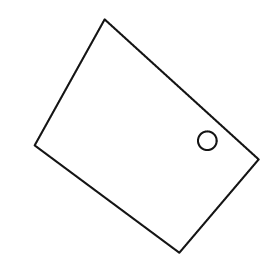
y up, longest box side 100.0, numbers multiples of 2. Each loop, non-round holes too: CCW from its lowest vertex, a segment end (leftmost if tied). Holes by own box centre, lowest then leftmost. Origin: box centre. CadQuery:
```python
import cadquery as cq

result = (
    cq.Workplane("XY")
    .moveTo(14.0, -50.0)
    .lineTo(48.0, -10.0)
    .lineTo(-18.0, 50.0)
    .lineTo(-48.0, -4.0)
    .close()
    .moveTo(26.0, -2.0)
    .circle(4.0)
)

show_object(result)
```